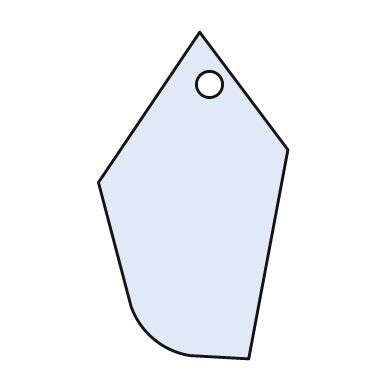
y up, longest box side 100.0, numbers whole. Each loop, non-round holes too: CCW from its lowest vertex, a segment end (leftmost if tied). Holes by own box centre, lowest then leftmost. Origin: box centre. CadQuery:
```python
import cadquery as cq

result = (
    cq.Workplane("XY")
    .moveTo(17.0, -50.0)
    .lineTo(29.0, 14.0)
    .lineTo(2.0, 50.0)
    .lineTo(-29.0, 4.0)
    .lineTo(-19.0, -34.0)
    .threePointArc((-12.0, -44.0), (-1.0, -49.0))
    .close()
    .moveTo(5.0, 34.0)
    .circle(4.0)
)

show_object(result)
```